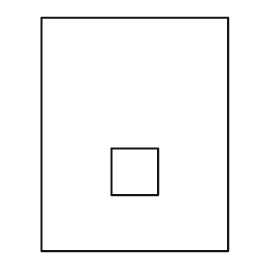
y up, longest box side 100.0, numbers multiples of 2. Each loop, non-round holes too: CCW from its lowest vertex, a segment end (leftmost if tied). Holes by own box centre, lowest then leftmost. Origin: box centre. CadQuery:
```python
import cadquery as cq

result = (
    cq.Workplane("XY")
    .moveTo(-40.0, -50.0)
    .lineTo(40.0, -50.0)
    .lineTo(40.0, 50.0)
    .lineTo(-40.0, 50.0)
    .close()
    .moveTo(-10.0, -26.0)
    .lineTo(10.0, -26.0)
    .lineTo(10.0, -6.0)
    .lineTo(-10.0, -6.0)
    .close()
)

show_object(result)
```